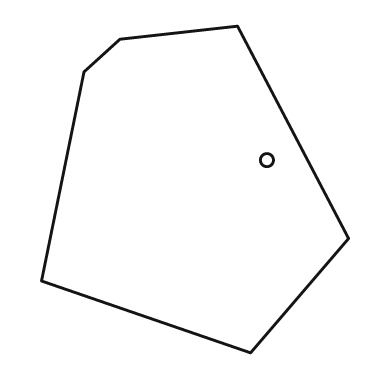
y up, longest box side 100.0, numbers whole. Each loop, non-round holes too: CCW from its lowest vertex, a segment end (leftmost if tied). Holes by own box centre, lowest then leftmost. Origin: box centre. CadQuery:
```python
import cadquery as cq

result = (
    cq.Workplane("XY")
    .moveTo(17.0, -50.0)
    .lineTo(47.0, -15.0)
    .lineTo(13.0, 50.0)
    .lineTo(-23.0, 46.0)
    .lineTo(-34.0, 36.0)
    .lineTo(-47.0, -28.0)
    .close()
    .moveTo(22.0, 9.0)
    .circle(2.0)
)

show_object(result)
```